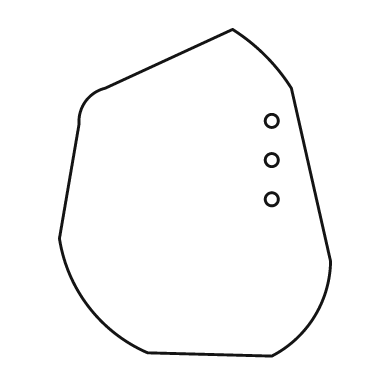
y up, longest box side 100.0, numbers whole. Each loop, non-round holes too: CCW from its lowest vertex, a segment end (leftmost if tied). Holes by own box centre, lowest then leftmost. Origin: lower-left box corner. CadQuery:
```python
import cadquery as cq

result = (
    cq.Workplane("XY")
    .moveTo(65.0, 0.0)
    .threePointArc((78.0, 12.0), (83.0, 29.0))
    .lineTo(71.0, 82.0)
    .threePointArc((63.0, 92.0), (53.0, 100.0))
    .lineTo(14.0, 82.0)
    .threePointArc((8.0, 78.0), (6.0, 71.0))
    .lineTo(0.0, 36.0)
    .threePointArc((9.0, 15.0), (27.0, 1.0))
    .close()
    .moveTo(65.0, 48.0)
    .circle(2.0)
    .moveTo(65.0, 60.0)
    .circle(2.0)
    .moveTo(65.0, 72.0)
    .circle(2.0)
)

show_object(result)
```